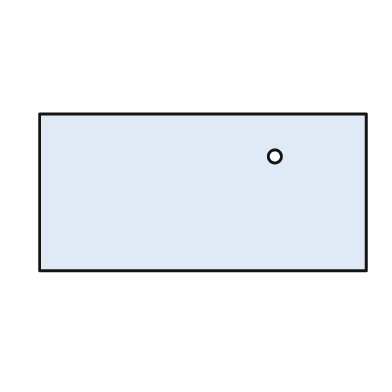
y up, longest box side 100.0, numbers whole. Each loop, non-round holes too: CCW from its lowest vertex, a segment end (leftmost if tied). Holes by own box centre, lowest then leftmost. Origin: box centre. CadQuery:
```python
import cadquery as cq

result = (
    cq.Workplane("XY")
    .moveTo(-50.0, -24.0)
    .lineTo(50.0, -24.0)
    .lineTo(50.0, 24.0)
    .lineTo(-50.0, 24.0)
    .close()
    .moveTo(22.0, 11.0)
    .circle(2.0)
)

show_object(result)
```